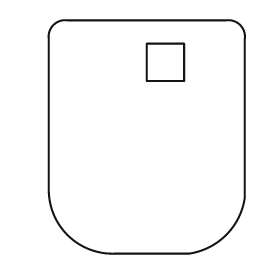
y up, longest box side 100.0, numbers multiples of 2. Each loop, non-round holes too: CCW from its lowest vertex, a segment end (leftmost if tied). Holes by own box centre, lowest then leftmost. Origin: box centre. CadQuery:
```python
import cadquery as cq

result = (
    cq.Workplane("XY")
    .moveTo(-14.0, -50.0)
    .lineTo(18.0, -50.0)
    .threePointArc((34.0, -42.0), (42.0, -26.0))
    .lineTo(42.0, 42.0)
    .threePointArc((40.0, 48.0), (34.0, 50.0))
    .lineTo(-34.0, 50.0)
    .threePointArc((-40.0, 48.0), (-42.0, 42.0))
    .lineTo(-42.0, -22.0)
    .threePointArc((-34.0, -42.0), (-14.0, -50.0))
    .close()
    .moveTo(0.0, 24.0)
    .lineTo(16.0, 24.0)
    .lineTo(16.0, 40.0)
    .lineTo(0.0, 40.0)
    .close()
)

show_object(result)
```